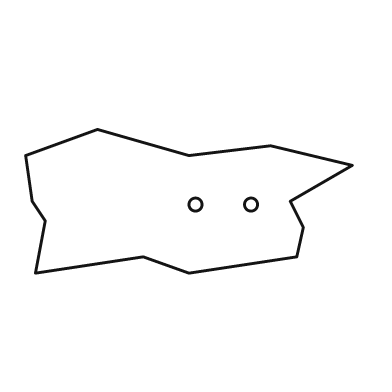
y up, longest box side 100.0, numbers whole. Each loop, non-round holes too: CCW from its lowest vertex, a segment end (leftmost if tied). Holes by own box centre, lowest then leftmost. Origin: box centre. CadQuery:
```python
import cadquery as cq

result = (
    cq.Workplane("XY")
    .moveTo(-47.0, -22.0)
    .lineTo(-14.0, -17.0)
    .lineTo(0.0, -22.0)
    .lineTo(33.0, -17.0)
    .lineTo(35.0, -8.0)
    .lineTo(31.0, 0.0)
    .lineTo(50.0, 11.0)
    .lineTo(25.0, 17.0)
    .lineTo(0.0, 14.0)
    .lineTo(-28.0, 22.0)
    .lineTo(-50.0, 14.0)
    .lineTo(-48.0, 0.0)
    .lineTo(-44.0, -6.0)
    .close()
    .moveTo(2.0, -1.0)
    .circle(2.0)
    .moveTo(19.0, -1.0)
    .circle(2.0)
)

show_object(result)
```